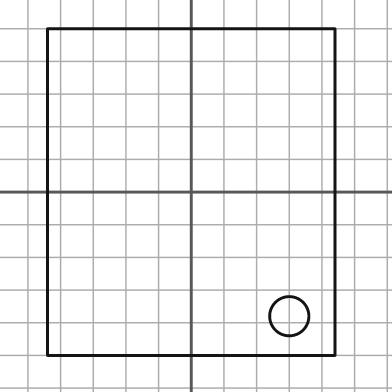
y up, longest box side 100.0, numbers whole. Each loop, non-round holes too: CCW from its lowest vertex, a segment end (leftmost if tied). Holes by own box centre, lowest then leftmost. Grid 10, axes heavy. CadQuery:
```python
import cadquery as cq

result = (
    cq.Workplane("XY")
    .moveTo(-44.0, -50.0)
    .lineTo(44.0, -50.0)
    .lineTo(44.0, 50.0)
    .lineTo(-44.0, 50.0)
    .close()
    .moveTo(30.0, -38.0)
    .circle(6.0)
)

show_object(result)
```